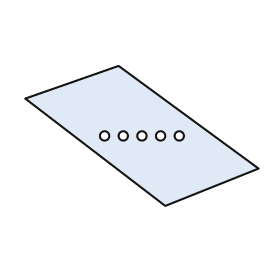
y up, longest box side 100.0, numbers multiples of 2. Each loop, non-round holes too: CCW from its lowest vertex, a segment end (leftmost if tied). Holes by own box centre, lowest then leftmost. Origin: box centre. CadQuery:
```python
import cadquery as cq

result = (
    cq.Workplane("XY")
    .moveTo(10.0, -30.0)
    .lineTo(50.0, -14.0)
    .lineTo(-10.0, 30.0)
    .lineTo(-50.0, 16.0)
    .close()
    .moveTo(-16.0, 0.0)
    .circle(2.0)
    .moveTo(-8.0, 0.0)
    .circle(2.0)
    .moveTo(0.0, 0.0)
    .circle(2.0)
    .moveTo(8.0, 0.0)
    .circle(2.0)
    .moveTo(16.0, 0.0)
    .circle(2.0)
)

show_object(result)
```